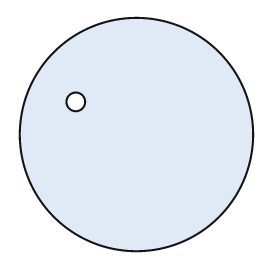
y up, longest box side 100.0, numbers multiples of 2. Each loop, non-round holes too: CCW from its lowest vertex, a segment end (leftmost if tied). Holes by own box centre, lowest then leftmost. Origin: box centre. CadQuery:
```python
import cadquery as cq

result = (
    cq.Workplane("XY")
    .moveTo(0.0, 0.0)
    .circle(50.0)
    .moveTo(-26.0, 14.0)
    .circle(4.0)
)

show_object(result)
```